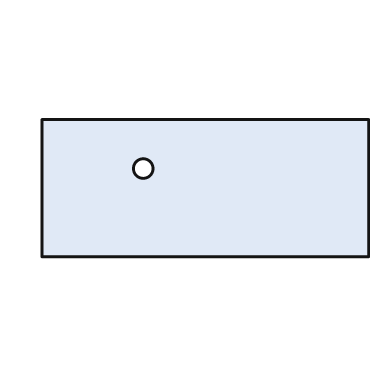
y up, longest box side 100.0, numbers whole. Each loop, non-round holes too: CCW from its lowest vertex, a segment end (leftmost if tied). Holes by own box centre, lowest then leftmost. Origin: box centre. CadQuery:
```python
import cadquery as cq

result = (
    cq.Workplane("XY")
    .moveTo(-50.0, -21.0)
    .lineTo(50.0, -21.0)
    .lineTo(50.0, 21.0)
    .lineTo(-50.0, 21.0)
    .close()
    .moveTo(-19.0, 6.0)
    .circle(3.0)
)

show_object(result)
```